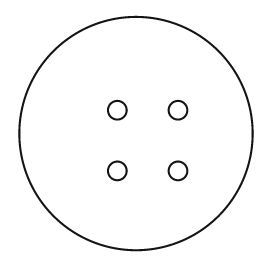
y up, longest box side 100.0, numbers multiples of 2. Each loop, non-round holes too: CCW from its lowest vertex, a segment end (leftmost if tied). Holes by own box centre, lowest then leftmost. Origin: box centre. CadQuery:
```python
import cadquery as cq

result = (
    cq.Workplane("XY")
    .moveTo(0.0, 0.0)
    .circle(50.0)
    .moveTo(-8.0, -16.0)
    .circle(4.0)
    .moveTo(18.0, -16.0)
    .circle(4.0)
    .moveTo(-8.0, 10.0)
    .circle(4.0)
    .moveTo(18.0, 10.0)
    .circle(4.0)
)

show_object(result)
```